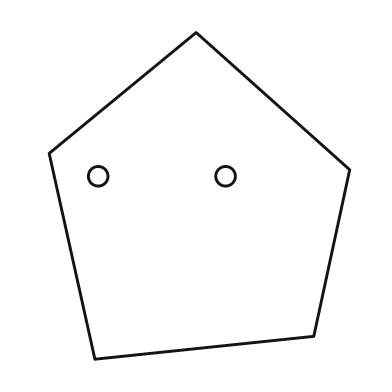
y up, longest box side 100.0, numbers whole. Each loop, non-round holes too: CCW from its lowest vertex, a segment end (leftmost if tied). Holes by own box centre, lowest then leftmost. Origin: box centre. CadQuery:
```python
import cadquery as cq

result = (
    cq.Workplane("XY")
    .moveTo(-32.0, -50.0)
    .lineTo(35.0, -43.0)
    .lineTo(46.0, 8.0)
    .lineTo(-1.0, 50.0)
    .lineTo(-46.0, 13.0)
    .close()
    .moveTo(-31.0, 6.0)
    .circle(3.0)
    .moveTo(8.0, 6.0)
    .circle(3.0)
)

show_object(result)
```